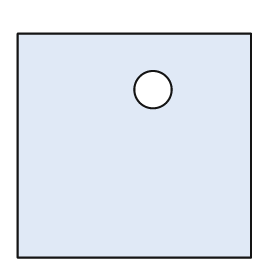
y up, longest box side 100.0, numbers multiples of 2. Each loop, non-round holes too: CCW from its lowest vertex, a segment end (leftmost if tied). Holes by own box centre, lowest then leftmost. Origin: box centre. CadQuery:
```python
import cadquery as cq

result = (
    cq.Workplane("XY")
    .moveTo(-50.0, -48.0)
    .lineTo(50.0, -48.0)
    .lineTo(50.0, 48.0)
    .lineTo(-50.0, 48.0)
    .close()
    .moveTo(8.0, 24.0)
    .circle(8.0)
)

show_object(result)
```